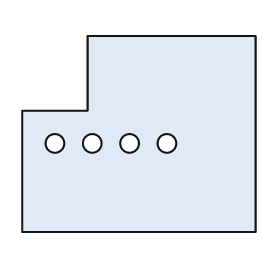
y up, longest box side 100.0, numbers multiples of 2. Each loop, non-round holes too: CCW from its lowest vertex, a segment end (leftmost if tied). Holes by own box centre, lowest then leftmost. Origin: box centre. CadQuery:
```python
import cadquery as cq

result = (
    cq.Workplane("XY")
    .moveTo(-50.0, -42.0)
    .lineTo(50.0, -42.0)
    .lineTo(50.0, 42.0)
    .lineTo(-22.0, 42.0)
    .lineTo(-22.0, 10.0)
    .lineTo(-50.0, 10.0)
    .close()
    .moveTo(-36.0, -4.0)
    .circle(4.0)
    .moveTo(-20.0, -4.0)
    .circle(4.0)
    .moveTo(-4.0, -4.0)
    .circle(4.0)
    .moveTo(12.0, -4.0)
    .circle(4.0)
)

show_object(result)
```